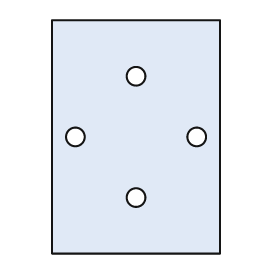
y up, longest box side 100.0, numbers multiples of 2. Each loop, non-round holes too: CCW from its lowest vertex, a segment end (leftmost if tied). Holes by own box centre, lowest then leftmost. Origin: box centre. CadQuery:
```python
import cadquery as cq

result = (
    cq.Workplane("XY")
    .moveTo(-36.0, -50.0)
    .lineTo(36.0, -50.0)
    .lineTo(36.0, 50.0)
    .lineTo(-36.0, 50.0)
    .close()
    .moveTo(0.0, -26.0)
    .circle(4.0)
    .moveTo(-26.0, 0.0)
    .circle(4.0)
    .moveTo(26.0, 0.0)
    .circle(4.0)
    .moveTo(0.0, 26.0)
    .circle(4.0)
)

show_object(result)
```